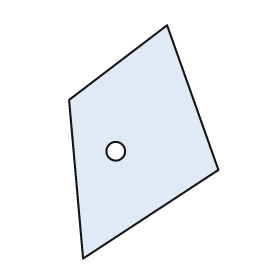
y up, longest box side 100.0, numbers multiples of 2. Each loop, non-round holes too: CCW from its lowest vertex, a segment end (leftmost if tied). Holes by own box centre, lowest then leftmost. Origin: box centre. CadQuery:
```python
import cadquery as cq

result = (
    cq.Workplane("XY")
    .moveTo(-26.0, -50.0)
    .lineTo(32.0, -12.0)
    .lineTo(10.0, 50.0)
    .lineTo(-32.0, 18.0)
    .close()
    .moveTo(-12.0, -4.0)
    .circle(4.0)
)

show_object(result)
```